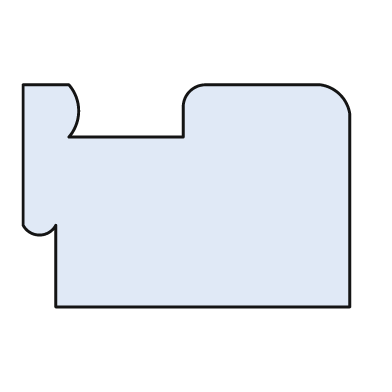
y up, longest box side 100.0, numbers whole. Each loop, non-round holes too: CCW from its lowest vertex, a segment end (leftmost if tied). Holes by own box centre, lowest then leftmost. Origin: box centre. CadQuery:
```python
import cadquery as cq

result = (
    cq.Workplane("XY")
    .moveTo(-40.0, -34.0)
    .lineTo(50.0, -34.0)
    .lineTo(50.0, 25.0)
    .threePointArc((47.0, 31.0), (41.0, 34.0))
    .lineTo(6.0, 34.0)
    .threePointArc((1.0, 32.0), (-1.0, 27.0))
    .lineTo(-1.0, 18.0)
    .lineTo(-36.0, 18.0)
    .threePointArc((-33.0, 26.0), (-36.0, 34.0))
    .lineTo(-50.0, 34.0)
    .lineTo(-50.0, -9.0)
    .threePointArc((-45.0, -12.0), (-40.0, -9.0))
    .close()
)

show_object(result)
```